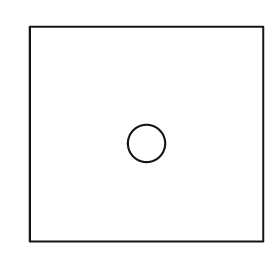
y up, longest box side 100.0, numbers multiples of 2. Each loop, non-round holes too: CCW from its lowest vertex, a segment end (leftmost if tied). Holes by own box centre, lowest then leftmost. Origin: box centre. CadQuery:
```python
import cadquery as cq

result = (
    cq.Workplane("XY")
    .moveTo(-50.0, -46.0)
    .lineTo(50.0, -46.0)
    .lineTo(50.0, 46.0)
    .lineTo(-50.0, 46.0)
    .close()
    .moveTo(0.0, -4.0)
    .circle(8.0)
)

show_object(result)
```